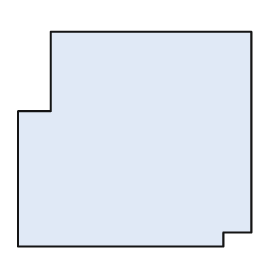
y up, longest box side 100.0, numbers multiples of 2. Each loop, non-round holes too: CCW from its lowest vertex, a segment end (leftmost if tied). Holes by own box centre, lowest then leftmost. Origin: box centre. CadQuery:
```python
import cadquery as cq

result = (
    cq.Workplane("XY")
    .moveTo(-50.0, -46.0)
    .lineTo(38.0, -46.0)
    .lineTo(38.0, -40.0)
    .lineTo(50.0, -40.0)
    .lineTo(50.0, 46.0)
    .lineTo(-36.0, 46.0)
    .lineTo(-36.0, 12.0)
    .lineTo(-50.0, 12.0)
    .close()
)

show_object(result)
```